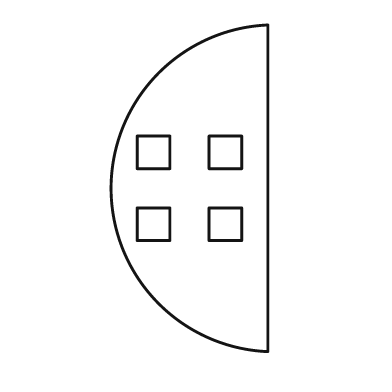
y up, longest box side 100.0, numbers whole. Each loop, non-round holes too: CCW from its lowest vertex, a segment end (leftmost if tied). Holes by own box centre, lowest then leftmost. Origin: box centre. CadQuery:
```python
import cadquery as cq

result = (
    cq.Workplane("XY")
    .moveTo(24.0, -50.0)
    .lineTo(24.0, 50.0)
    .threePointArc((-24.0, 0.0), (24.0, -50.0))
    .close()
    .moveTo(-16.0, -16.0)
    .lineTo(-6.0, -16.0)
    .lineTo(-6.0, -6.0)
    .lineTo(-16.0, -6.0)
    .close()
    .moveTo(6.0, -16.0)
    .lineTo(16.0, -16.0)
    .lineTo(16.0, -6.0)
    .lineTo(6.0, -6.0)
    .close()
    .moveTo(-16.0, 6.0)
    .lineTo(-6.0, 6.0)
    .lineTo(-6.0, 16.0)
    .lineTo(-16.0, 16.0)
    .close()
    .moveTo(6.0, 6.0)
    .lineTo(16.0, 6.0)
    .lineTo(16.0, 16.0)
    .lineTo(6.0, 16.0)
    .close()
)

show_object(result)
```